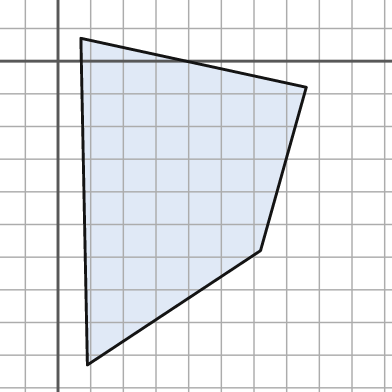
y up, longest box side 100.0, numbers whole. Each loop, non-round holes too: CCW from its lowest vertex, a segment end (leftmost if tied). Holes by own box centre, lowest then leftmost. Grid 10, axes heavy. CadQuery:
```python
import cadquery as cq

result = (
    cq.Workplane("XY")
    .moveTo(9.0, -93.0)
    .lineTo(62.0, -58.0)
    .lineTo(76.0, -8.0)
    .lineTo(7.0, 7.0)
    .close()
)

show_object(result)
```